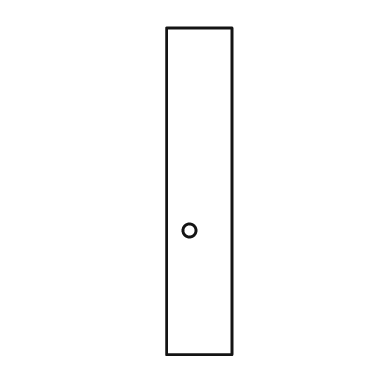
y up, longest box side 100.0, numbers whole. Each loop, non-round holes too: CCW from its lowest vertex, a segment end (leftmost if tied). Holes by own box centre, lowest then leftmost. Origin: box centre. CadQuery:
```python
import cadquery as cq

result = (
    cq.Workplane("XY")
    .moveTo(-10.0, -50.0)
    .lineTo(10.0, -50.0)
    .lineTo(10.0, 50.0)
    .lineTo(-10.0, 50.0)
    .close()
    .moveTo(-3.0, -12.0)
    .circle(2.0)
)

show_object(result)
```